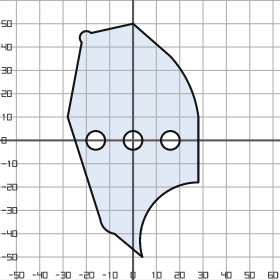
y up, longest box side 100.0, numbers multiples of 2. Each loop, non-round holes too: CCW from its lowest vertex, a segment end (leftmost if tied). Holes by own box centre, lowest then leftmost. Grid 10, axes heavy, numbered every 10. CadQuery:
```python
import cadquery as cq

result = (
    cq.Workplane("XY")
    .moveTo(4.0, -50.0)
    .threePointArc((8.0, -28.0), (28.0, -18.0))
    .lineTo(28.0, 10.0)
    .threePointArc((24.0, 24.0), (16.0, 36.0))
    .lineTo(0.0, 50.0)
    .lineTo(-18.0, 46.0)
    .threePointArc((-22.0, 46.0), (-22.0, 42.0))
    .lineTo(-28.0, 10.0)
    .lineTo(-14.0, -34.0)
    .threePointArc((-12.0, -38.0), (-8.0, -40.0))
    .close()
    .moveTo(-16.0, 0.0)
    .circle(4.0)
    .moveTo(0.0, 0.0)
    .circle(4.0)
    .moveTo(16.0, 0.0)
    .circle(4.0)
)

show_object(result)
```